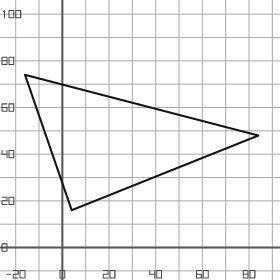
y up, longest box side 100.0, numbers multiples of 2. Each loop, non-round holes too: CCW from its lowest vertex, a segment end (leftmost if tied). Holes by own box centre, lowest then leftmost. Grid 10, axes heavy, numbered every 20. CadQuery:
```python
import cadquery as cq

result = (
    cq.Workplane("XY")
    .moveTo(4.0, 16.0)
    .lineTo(84.0, 48.0)
    .lineTo(-16.0, 74.0)
    .close()
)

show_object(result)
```